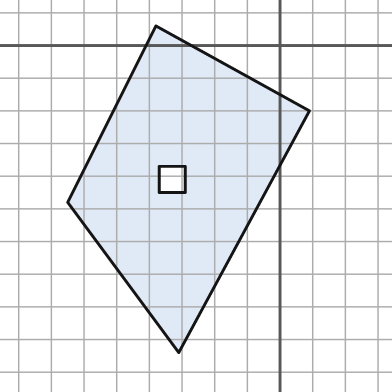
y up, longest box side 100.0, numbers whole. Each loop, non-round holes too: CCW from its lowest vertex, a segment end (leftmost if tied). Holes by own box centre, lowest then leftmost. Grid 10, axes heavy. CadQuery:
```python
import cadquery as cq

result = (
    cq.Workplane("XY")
    .moveTo(-31.0, -94.0)
    .lineTo(9.0, -20.0)
    .lineTo(-38.0, 6.0)
    .lineTo(-65.0, -48.0)
    .close()
    .moveTo(-37.0, -45.0)
    .lineTo(-29.0, -45.0)
    .lineTo(-29.0, -37.0)
    .lineTo(-37.0, -37.0)
    .close()
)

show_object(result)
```